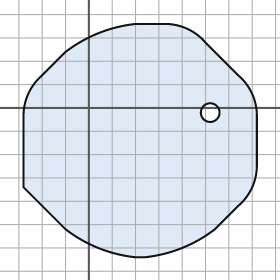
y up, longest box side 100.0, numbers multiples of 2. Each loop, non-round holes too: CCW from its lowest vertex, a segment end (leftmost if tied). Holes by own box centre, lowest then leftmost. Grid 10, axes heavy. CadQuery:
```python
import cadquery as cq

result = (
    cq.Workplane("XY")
    .moveTo(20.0, -64.0)
    .lineTo(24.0, -64.0)
    .threePointArc((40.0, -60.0), (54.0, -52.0))
    .lineTo(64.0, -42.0)
    .threePointArc((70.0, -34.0), (72.0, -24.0))
    .lineTo(72.0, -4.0)
    .threePointArc((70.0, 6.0), (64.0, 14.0))
    .lineTo(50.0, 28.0)
    .threePointArc((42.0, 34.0), (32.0, 36.0))
    .lineTo(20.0, 36.0)
    .threePointArc((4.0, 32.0), (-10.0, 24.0))
    .lineTo(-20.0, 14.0)
    .threePointArc((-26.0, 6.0), (-28.0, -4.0))
    .lineTo(-28.0, -34.0)
    .lineTo(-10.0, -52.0)
    .threePointArc((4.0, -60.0), (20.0, -64.0))
    .close()
    .moveTo(52.0, -2.0)
    .circle(4.0)
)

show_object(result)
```